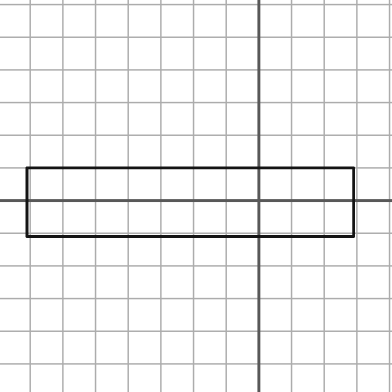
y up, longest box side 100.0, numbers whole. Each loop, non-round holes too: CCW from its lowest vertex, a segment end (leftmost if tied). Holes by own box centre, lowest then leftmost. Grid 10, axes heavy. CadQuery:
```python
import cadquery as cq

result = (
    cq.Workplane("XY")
    .moveTo(-71.0, -11.0)
    .lineTo(29.0, -11.0)
    .lineTo(29.0, 10.0)
    .lineTo(-71.0, 10.0)
    .close()
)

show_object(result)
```